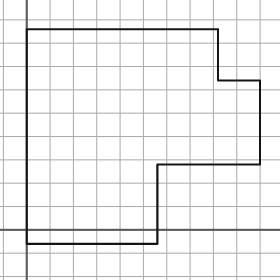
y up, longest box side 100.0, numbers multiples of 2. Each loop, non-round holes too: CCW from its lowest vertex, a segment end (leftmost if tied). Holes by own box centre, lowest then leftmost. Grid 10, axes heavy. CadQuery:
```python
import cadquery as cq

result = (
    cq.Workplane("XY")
    .moveTo(0.0, -6.0)
    .lineTo(56.0, -6.0)
    .lineTo(56.0, 28.0)
    .lineTo(100.0, 28.0)
    .lineTo(100.0, 64.0)
    .lineTo(82.0, 64.0)
    .lineTo(82.0, 86.0)
    .lineTo(0.0, 86.0)
    .close()
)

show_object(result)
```